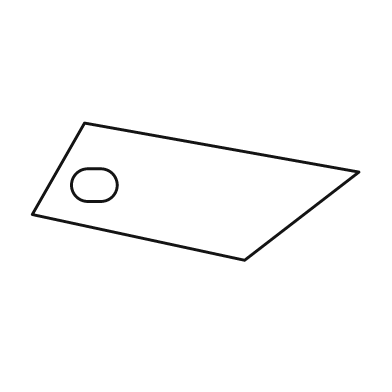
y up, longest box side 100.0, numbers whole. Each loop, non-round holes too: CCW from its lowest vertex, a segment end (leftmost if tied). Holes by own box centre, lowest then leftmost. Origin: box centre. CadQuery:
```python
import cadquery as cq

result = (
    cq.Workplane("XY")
    .moveTo(15.0, -21.0)
    .lineTo(50.0, 6.0)
    .lineTo(-34.0, 21.0)
    .lineTo(-50.0, -7.0)
    .close()
    .moveTo(-33.0, -3.0)
    .lineTo(-29.0, -3.0)
    .threePointArc((-24.0, 2.0), (-29.0, 7.0))
    .lineTo(-33.0, 7.0)
    .threePointArc((-38.0, 2.0), (-33.0, -3.0))
    .close()
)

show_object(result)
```